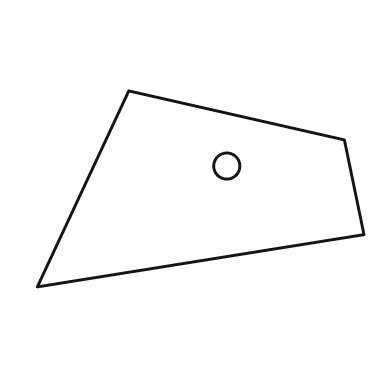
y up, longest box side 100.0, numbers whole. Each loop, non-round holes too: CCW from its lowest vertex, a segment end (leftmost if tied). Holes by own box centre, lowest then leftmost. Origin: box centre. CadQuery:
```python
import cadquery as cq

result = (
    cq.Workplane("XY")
    .moveTo(-50.0, -30.0)
    .lineTo(50.0, -14.0)
    .lineTo(44.0, 15.0)
    .lineTo(-22.0, 30.0)
    .close()
    .moveTo(8.0, 7.0)
    .circle(4.0)
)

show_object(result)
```